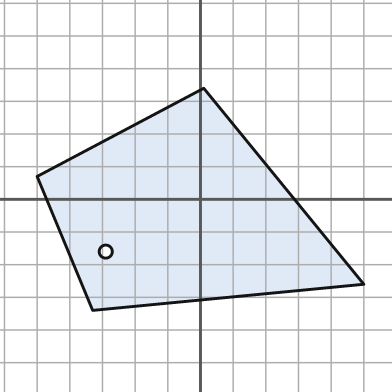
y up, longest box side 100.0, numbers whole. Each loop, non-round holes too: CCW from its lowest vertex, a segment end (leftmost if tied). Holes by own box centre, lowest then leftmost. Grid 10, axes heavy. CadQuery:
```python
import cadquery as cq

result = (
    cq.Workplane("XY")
    .moveTo(-33.0, -34.0)
    .lineTo(50.0, -26.0)
    .lineTo(1.0, 34.0)
    .lineTo(-50.0, 7.0)
    .close()
    .moveTo(-29.0, -16.0)
    .circle(2.0)
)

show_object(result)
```